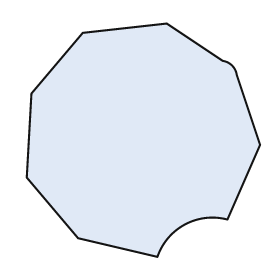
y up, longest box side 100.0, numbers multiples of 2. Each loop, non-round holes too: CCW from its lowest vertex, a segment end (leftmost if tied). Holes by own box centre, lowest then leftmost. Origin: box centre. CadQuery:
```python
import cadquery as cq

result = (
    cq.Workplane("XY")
    .moveTo(6.0, -50.0)
    .threePointArc((18.0, -36.0), (36.0, -34.0))
    .lineTo(50.0, -2.0)
    .lineTo(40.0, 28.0)
    .threePointArc((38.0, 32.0), (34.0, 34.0))
    .lineTo(10.0, 50.0)
    .lineTo(-26.0, 46.0)
    .lineTo(-48.0, 20.0)
    .lineTo(-50.0, -16.0)
    .lineTo(-28.0, -42.0)
    .close()
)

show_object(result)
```